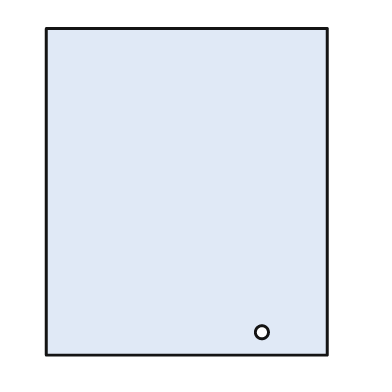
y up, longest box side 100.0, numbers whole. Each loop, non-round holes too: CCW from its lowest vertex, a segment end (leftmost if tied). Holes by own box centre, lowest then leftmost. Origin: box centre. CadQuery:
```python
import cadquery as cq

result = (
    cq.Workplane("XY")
    .moveTo(-43.0, -50.0)
    .lineTo(43.0, -50.0)
    .lineTo(43.0, 50.0)
    .lineTo(-43.0, 50.0)
    .close()
    .moveTo(23.0, -43.0)
    .circle(2.0)
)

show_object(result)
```